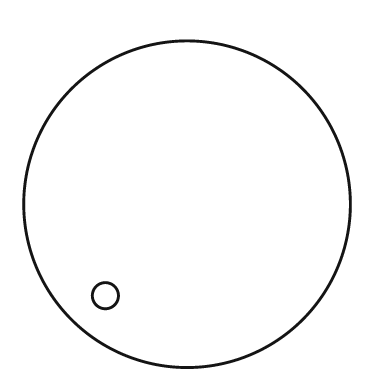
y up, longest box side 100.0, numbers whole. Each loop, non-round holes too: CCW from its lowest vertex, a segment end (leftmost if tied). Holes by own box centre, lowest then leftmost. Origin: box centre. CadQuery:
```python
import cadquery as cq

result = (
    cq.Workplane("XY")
    .moveTo(0.0, 0.0)
    .circle(50.0)
    .moveTo(-25.0, -28.0)
    .circle(4.0)
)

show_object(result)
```